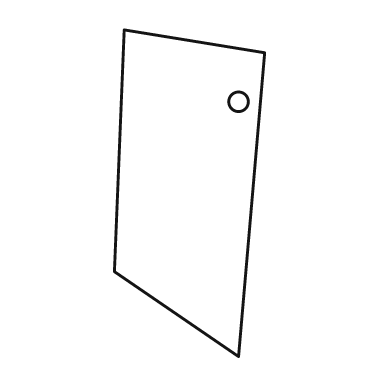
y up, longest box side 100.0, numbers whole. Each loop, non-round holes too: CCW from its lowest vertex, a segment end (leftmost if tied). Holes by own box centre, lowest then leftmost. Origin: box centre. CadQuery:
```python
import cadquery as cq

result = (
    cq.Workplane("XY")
    .moveTo(15.0, -50.0)
    .lineTo(23.0, 43.0)
    .lineTo(-20.0, 50.0)
    .lineTo(-23.0, -24.0)
    .close()
    .moveTo(15.0, 28.0)
    .circle(3.0)
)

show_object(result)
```